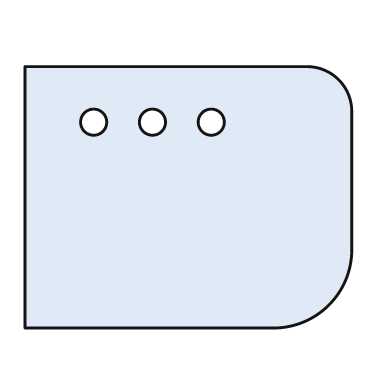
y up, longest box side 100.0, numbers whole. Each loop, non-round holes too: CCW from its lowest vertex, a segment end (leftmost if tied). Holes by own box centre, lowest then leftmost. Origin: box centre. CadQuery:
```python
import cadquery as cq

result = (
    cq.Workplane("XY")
    .moveTo(-50.0, -40.0)
    .lineTo(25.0, -40.0)
    .threePointArc((43.0, -33.0), (50.0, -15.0))
    .lineTo(50.0, 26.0)
    .threePointArc((46.0, 36.0), (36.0, 40.0))
    .lineTo(-50.0, 40.0)
    .close()
    .moveTo(-29.0, 23.0)
    .circle(4.0)
    .moveTo(-11.0, 23.0)
    .circle(4.0)
    .moveTo(7.0, 23.0)
    .circle(4.0)
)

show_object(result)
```